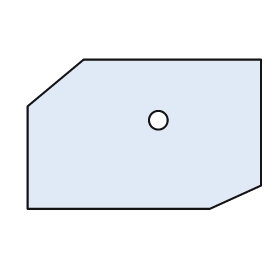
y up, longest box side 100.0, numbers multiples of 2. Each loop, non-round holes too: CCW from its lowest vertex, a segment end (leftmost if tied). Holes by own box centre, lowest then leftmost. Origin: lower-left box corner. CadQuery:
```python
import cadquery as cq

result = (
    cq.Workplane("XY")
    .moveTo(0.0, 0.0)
    .lineTo(78.0, 0.0)
    .lineTo(100.0, 10.0)
    .lineTo(100.0, 64.0)
    .lineTo(24.0, 64.0)
    .lineTo(0.0, 44.0)
    .close()
    .moveTo(56.0, 38.0)
    .circle(4.0)
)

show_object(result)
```